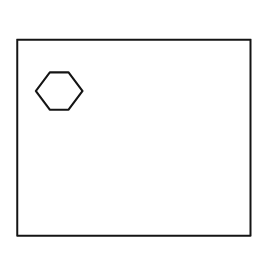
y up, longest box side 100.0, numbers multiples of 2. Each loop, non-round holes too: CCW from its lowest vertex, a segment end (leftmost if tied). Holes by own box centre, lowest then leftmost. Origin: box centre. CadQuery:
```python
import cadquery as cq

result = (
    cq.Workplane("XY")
    .moveTo(-50.0, -42.0)
    .lineTo(50.0, -42.0)
    .lineTo(50.0, 42.0)
    .lineTo(-50.0, 42.0)
    .close()
    .moveTo(-36.0, 12.0)
    .lineTo(-28.0, 12.0)
    .lineTo(-22.0, 20.0)
    .lineTo(-28.0, 28.0)
    .lineTo(-36.0, 28.0)
    .lineTo(-42.0, 20.0)
    .close()
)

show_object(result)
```